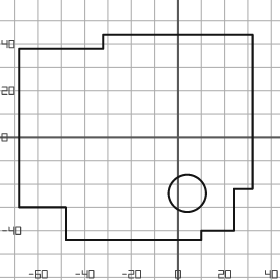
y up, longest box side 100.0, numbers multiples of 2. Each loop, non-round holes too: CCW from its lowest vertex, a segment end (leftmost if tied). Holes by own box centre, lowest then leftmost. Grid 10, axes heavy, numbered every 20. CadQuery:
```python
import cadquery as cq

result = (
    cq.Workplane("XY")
    .moveTo(-48.0, -44.0)
    .lineTo(10.0, -44.0)
    .lineTo(10.0, -40.0)
    .lineTo(24.0, -40.0)
    .lineTo(24.0, -22.0)
    .lineTo(32.0, -22.0)
    .lineTo(32.0, 44.0)
    .lineTo(-32.0, 44.0)
    .lineTo(-32.0, 38.0)
    .lineTo(-68.0, 38.0)
    .lineTo(-68.0, -30.0)
    .lineTo(-48.0, -30.0)
    .close()
    .moveTo(4.0, -24.0)
    .circle(8.0)
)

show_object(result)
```